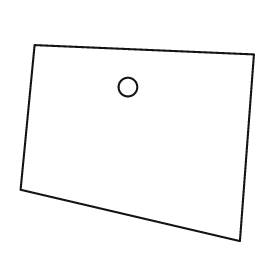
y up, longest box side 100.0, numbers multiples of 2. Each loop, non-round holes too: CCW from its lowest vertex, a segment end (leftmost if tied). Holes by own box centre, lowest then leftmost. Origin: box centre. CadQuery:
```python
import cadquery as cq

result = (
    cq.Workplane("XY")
    .moveTo(44.0, -42.0)
    .lineTo(50.0, 38.0)
    .lineTo(-44.0, 42.0)
    .lineTo(-50.0, -20.0)
    .close()
    .moveTo(-4.0, 24.0)
    .circle(4.0)
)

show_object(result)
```